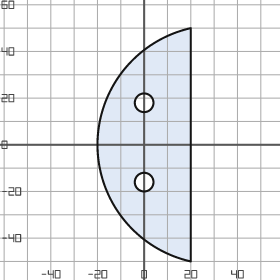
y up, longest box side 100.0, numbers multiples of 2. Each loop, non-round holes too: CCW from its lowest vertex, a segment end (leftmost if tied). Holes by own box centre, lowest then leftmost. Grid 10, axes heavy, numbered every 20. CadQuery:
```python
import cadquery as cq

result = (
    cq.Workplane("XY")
    .moveTo(20.0, -50.0)
    .lineTo(20.0, 50.0)
    .threePointArc((-20.0, 0.0), (20.0, -50.0))
    .close()
    .moveTo(0.0, -16.0)
    .circle(4.0)
    .moveTo(0.0, 18.0)
    .circle(4.0)
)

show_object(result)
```